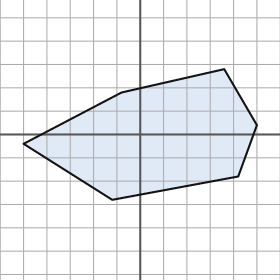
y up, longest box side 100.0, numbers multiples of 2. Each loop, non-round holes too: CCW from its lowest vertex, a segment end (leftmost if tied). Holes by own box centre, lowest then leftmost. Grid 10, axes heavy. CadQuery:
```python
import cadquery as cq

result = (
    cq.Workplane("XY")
    .moveTo(-12.0, -28.0)
    .lineTo(42.0, -18.0)
    .lineTo(50.0, 4.0)
    .lineTo(36.0, 28.0)
    .lineTo(-8.0, 18.0)
    .lineTo(-50.0, -4.0)
    .close()
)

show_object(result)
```